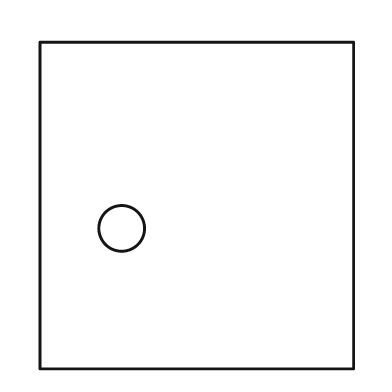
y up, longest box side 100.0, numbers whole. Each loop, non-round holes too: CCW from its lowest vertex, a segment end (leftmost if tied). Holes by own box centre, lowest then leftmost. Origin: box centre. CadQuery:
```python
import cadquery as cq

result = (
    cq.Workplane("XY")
    .moveTo(-48.0, -50.0)
    .lineTo(48.0, -50.0)
    .lineTo(48.0, 50.0)
    .lineTo(-48.0, 50.0)
    .close()
    .moveTo(-23.0, -7.0)
    .circle(7.0)
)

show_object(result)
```